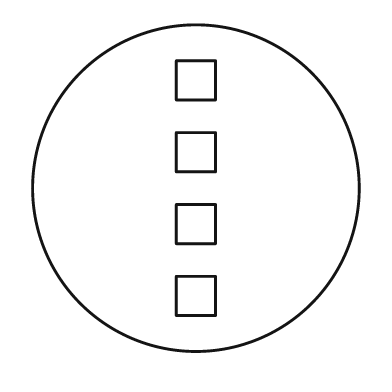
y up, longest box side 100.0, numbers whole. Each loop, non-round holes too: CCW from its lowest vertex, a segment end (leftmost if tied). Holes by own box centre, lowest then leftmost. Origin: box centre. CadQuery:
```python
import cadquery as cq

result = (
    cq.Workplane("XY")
    .moveTo(0.0, 0.0)
    .circle(50.0)
    .moveTo(-6.0, -39.0)
    .lineTo(6.0, -39.0)
    .lineTo(6.0, -27.0)
    .lineTo(-6.0, -27.0)
    .close()
    .moveTo(-6.0, -17.0)
    .lineTo(6.0, -17.0)
    .lineTo(6.0, -5.0)
    .lineTo(-6.0, -5.0)
    .close()
    .moveTo(-6.0, 5.0)
    .lineTo(6.0, 5.0)
    .lineTo(6.0, 17.0)
    .lineTo(-6.0, 17.0)
    .close()
    .moveTo(-6.0, 27.0)
    .lineTo(6.0, 27.0)
    .lineTo(6.0, 39.0)
    .lineTo(-6.0, 39.0)
    .close()
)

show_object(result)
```